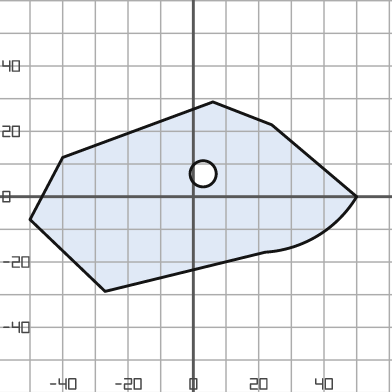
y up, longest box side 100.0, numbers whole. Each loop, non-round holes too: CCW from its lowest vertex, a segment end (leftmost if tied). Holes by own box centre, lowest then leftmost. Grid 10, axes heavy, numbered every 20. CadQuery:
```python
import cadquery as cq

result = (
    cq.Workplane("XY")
    .moveTo(-27.0, -29.0)
    .lineTo(22.0, -17.0)
    .threePointArc((38.0, -12.0), (50.0, 0.0))
    .lineTo(24.0, 22.0)
    .lineTo(6.0, 29.0)
    .lineTo(-40.0, 12.0)
    .lineTo(-50.0, -7.0)
    .close()
    .moveTo(3.0, 7.0)
    .circle(4.0)
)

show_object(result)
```